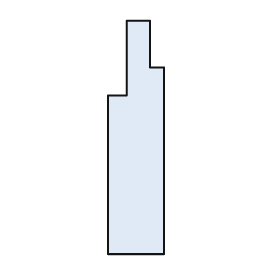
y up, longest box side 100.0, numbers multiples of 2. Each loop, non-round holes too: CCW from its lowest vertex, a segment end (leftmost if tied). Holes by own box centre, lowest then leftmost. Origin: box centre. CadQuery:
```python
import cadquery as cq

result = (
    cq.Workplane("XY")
    .moveTo(-12.0, -50.0)
    .lineTo(12.0, -50.0)
    .lineTo(12.0, 30.0)
    .lineTo(6.0, 30.0)
    .lineTo(6.0, 50.0)
    .lineTo(-4.0, 50.0)
    .lineTo(-4.0, 18.0)
    .lineTo(-12.0, 18.0)
    .close()
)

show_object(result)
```